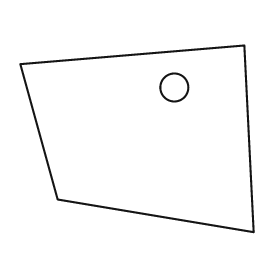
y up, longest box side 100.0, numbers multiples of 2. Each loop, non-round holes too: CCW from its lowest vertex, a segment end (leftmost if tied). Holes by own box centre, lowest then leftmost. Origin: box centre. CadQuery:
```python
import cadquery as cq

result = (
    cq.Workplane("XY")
    .moveTo(50.0, -40.0)
    .lineTo(46.0, 40.0)
    .lineTo(-50.0, 32.0)
    .lineTo(-34.0, -26.0)
    .close()
    .moveTo(16.0, 22.0)
    .circle(6.0)
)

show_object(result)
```